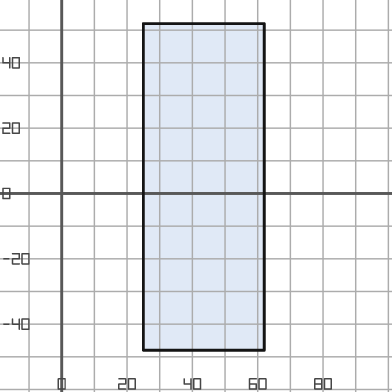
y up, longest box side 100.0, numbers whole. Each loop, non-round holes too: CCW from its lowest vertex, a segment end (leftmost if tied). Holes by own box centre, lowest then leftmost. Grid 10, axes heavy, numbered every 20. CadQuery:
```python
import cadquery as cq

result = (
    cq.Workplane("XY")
    .moveTo(25.0, -48.0)
    .lineTo(62.0, -48.0)
    .lineTo(62.0, 52.0)
    .lineTo(25.0, 52.0)
    .close()
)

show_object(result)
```